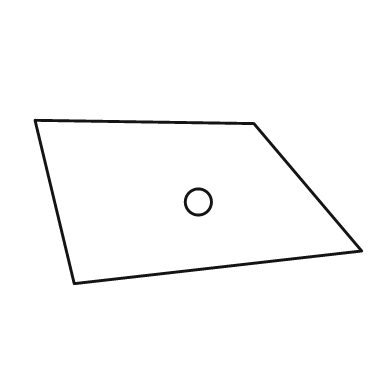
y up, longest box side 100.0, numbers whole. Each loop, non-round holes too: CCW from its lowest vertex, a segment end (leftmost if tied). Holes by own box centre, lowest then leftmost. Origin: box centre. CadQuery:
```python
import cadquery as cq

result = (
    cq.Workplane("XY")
    .moveTo(-38.0, -25.0)
    .lineTo(50.0, -15.0)
    .lineTo(17.0, 24.0)
    .lineTo(-50.0, 25.0)
    .close()
    .moveTo(0.0, 0.0)
    .circle(4.0)
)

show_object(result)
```